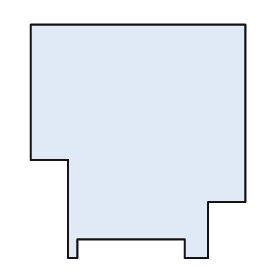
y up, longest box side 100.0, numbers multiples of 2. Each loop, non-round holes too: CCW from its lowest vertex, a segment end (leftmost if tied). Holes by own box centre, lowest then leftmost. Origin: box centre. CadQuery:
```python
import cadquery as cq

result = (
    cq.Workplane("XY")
    .moveTo(-30.0, -50.0)
    .lineTo(-26.0, -50.0)
    .lineTo(-26.0, -42.0)
    .lineTo(20.0, -42.0)
    .lineTo(20.0, -50.0)
    .lineTo(30.0, -50.0)
    .lineTo(30.0, -26.0)
    .lineTo(46.0, -26.0)
    .lineTo(46.0, 50.0)
    .lineTo(-46.0, 50.0)
    .lineTo(-46.0, -8.0)
    .lineTo(-30.0, -8.0)
    .close()
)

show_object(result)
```